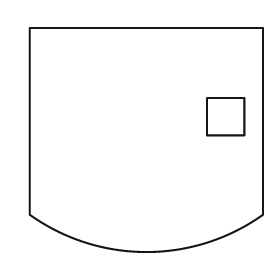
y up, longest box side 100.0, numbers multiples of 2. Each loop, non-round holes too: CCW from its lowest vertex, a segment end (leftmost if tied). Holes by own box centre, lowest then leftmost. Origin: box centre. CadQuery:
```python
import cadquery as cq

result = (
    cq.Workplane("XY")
    .moveTo(-50.0, -32.0)
    .threePointArc((0.0, -48.0), (50.0, -32.0))
    .lineTo(50.0, 48.0)
    .lineTo(-50.0, 48.0)
    .close()
    .moveTo(26.0, 2.0)
    .lineTo(42.0, 2.0)
    .lineTo(42.0, 18.0)
    .lineTo(26.0, 18.0)
    .close()
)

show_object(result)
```